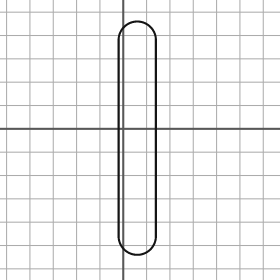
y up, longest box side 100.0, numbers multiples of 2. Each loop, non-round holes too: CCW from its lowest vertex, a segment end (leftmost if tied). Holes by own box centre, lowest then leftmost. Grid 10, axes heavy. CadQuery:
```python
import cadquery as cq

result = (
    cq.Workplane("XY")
    .moveTo(-2.0, -46.0)
    .threePointArc((6.0, -54.0), (14.0, -46.0))
    .lineTo(14.0, 38.0)
    .threePointArc((6.0, 46.0), (-2.0, 38.0))
    .close()
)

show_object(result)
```